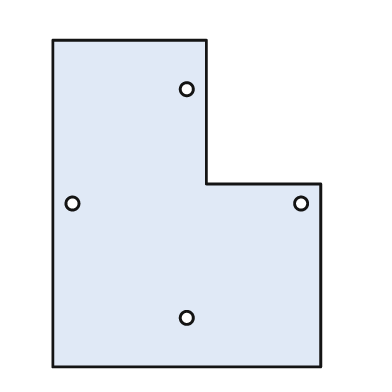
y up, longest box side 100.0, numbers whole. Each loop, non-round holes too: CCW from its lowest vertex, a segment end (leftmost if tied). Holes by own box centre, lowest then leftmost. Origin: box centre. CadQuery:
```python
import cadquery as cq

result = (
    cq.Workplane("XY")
    .moveTo(-41.0, -50.0)
    .lineTo(41.0, -50.0)
    .lineTo(41.0, 6.0)
    .lineTo(6.0, 6.0)
    .lineTo(6.0, 50.0)
    .lineTo(-41.0, 50.0)
    .close()
    .moveTo(0.0, -35.0)
    .circle(2.0)
    .moveTo(-35.0, 0.0)
    .circle(2.0)
    .moveTo(35.0, 0.0)
    .circle(2.0)
    .moveTo(0.0, 35.0)
    .circle(2.0)
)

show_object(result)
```